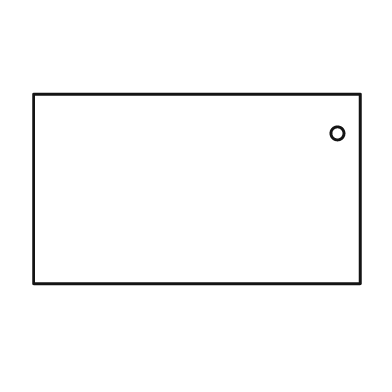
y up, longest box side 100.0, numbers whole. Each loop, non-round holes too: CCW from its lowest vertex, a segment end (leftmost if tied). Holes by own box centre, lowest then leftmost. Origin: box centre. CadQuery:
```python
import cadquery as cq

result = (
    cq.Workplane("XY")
    .moveTo(-50.0, -29.0)
    .lineTo(50.0, -29.0)
    .lineTo(50.0, 29.0)
    .lineTo(-50.0, 29.0)
    .close()
    .moveTo(43.0, 17.0)
    .circle(2.0)
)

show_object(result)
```